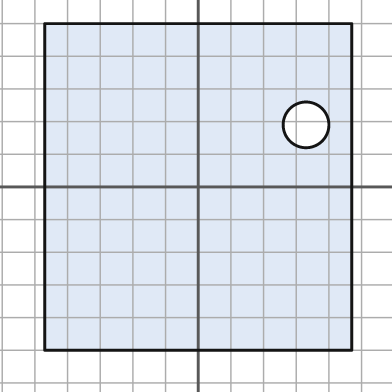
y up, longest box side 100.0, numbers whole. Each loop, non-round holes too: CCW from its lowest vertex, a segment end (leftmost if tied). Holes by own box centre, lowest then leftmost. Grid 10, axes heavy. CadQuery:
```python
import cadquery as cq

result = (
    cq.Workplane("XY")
    .moveTo(-47.0, -50.0)
    .lineTo(47.0, -50.0)
    .lineTo(47.0, 50.0)
    .lineTo(-47.0, 50.0)
    .close()
    .moveTo(33.0, 19.0)
    .circle(7.0)
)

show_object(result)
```